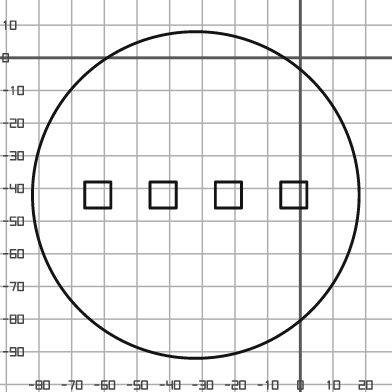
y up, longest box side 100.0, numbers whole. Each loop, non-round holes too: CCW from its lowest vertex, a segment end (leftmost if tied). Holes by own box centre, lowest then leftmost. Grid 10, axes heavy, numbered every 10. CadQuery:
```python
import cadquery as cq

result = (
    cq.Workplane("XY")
    .moveTo(-32.0, -42.0)
    .circle(50.0)
    .moveTo(-66.0, -46.0)
    .lineTo(-58.0, -46.0)
    .lineTo(-58.0, -38.0)
    .lineTo(-66.0, -38.0)
    .close()
    .moveTo(-46.0, -46.0)
    .lineTo(-38.0, -46.0)
    .lineTo(-38.0, -38.0)
    .lineTo(-46.0, -38.0)
    .close()
    .moveTo(-26.0, -46.0)
    .lineTo(-18.0, -46.0)
    .lineTo(-18.0, -38.0)
    .lineTo(-26.0, -38.0)
    .close()
    .moveTo(-6.0, -46.0)
    .lineTo(2.0, -46.0)
    .lineTo(2.0, -38.0)
    .lineTo(-6.0, -38.0)
    .close()
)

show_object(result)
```